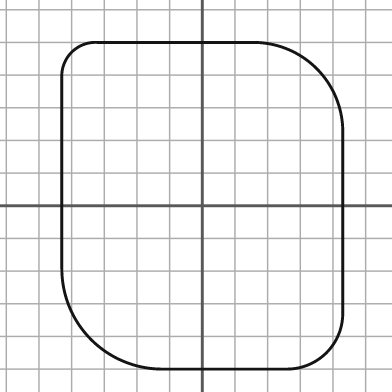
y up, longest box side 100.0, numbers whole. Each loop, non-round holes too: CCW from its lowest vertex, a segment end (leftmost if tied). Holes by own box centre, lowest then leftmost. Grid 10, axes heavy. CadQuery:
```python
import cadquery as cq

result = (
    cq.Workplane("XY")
    .moveTo(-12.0, -50.0)
    .lineTo(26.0, -50.0)
    .threePointArc((38.0, -45.0), (43.0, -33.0))
    .lineTo(43.0, 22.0)
    .threePointArc((35.0, 42.0), (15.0, 50.0))
    .lineTo(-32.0, 50.0)
    .threePointArc((-40.0, 47.0), (-43.0, 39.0))
    .lineTo(-43.0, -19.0)
    .threePointArc((-34.0, -41.0), (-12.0, -50.0))
    .close()
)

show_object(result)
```